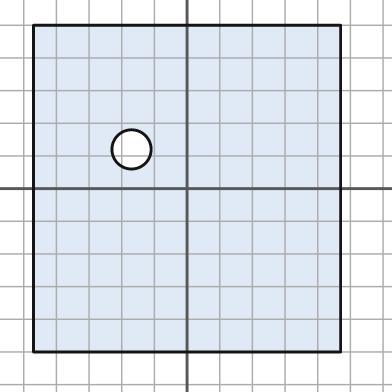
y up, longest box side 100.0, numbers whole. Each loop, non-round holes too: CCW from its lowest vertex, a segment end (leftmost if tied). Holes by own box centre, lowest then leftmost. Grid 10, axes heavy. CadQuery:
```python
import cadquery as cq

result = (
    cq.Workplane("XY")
    .moveTo(-47.0, -50.0)
    .lineTo(47.0, -50.0)
    .lineTo(47.0, 50.0)
    .lineTo(-47.0, 50.0)
    .close()
    .moveTo(-17.0, 12.0)
    .circle(6.0)
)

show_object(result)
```